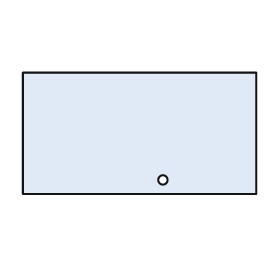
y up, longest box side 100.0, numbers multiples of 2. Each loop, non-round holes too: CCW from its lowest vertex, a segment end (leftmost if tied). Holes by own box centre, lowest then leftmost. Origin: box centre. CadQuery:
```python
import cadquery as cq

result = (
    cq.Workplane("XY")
    .moveTo(-50.0, -26.0)
    .lineTo(50.0, -26.0)
    .lineTo(50.0, 26.0)
    .lineTo(-50.0, 26.0)
    .close()
    .moveTo(10.0, -20.0)
    .circle(2.0)
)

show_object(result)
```